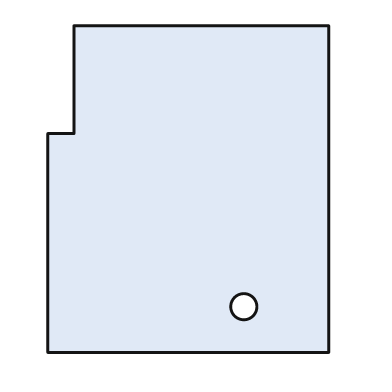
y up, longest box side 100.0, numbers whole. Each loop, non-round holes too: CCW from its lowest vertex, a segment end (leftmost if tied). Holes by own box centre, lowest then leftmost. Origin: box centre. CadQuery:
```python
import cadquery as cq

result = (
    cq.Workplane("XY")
    .moveTo(-43.0, -50.0)
    .lineTo(43.0, -50.0)
    .lineTo(43.0, 50.0)
    .lineTo(-35.0, 50.0)
    .lineTo(-35.0, 17.0)
    .lineTo(-43.0, 17.0)
    .close()
    .moveTo(17.0, -36.0)
    .circle(4.0)
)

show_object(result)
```